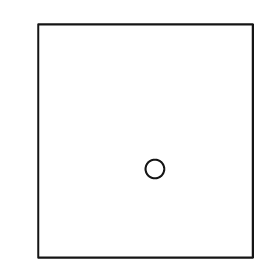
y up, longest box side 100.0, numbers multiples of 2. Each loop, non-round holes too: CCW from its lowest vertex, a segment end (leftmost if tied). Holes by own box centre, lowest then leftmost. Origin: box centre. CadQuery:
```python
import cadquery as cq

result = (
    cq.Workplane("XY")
    .moveTo(-46.0, -50.0)
    .lineTo(46.0, -50.0)
    .lineTo(46.0, 50.0)
    .lineTo(-46.0, 50.0)
    .close()
    .moveTo(4.0, -12.0)
    .circle(4.0)
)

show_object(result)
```